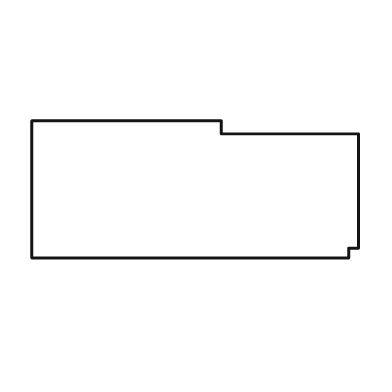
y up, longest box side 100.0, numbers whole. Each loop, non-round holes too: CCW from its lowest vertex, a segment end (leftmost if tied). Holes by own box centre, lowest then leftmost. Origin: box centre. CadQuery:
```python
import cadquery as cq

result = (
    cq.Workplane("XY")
    .moveTo(-50.0, -21.0)
    .lineTo(47.0, -21.0)
    .lineTo(47.0, -18.0)
    .lineTo(50.0, -18.0)
    .lineTo(50.0, 17.0)
    .lineTo(8.0, 17.0)
    .lineTo(8.0, 21.0)
    .lineTo(-50.0, 21.0)
    .close()
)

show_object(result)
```